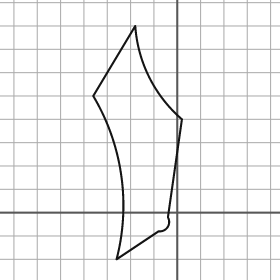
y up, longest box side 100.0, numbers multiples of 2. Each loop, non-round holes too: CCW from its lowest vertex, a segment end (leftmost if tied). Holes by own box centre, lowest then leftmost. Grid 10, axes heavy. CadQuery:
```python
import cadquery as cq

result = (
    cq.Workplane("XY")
    .moveTo(-26.0, -20.0)
    .lineTo(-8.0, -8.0)
    .threePointArc((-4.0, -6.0), (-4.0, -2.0))
    .lineTo(2.0, 40.0)
    .threePointArc((-12.0, 58.0), (-18.0, 80.0))
    .lineTo(-36.0, 50.0)
    .threePointArc((-24.0, 16.0), (-26.0, -20.0))
    .close()
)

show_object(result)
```